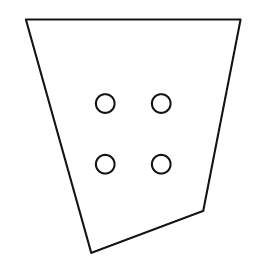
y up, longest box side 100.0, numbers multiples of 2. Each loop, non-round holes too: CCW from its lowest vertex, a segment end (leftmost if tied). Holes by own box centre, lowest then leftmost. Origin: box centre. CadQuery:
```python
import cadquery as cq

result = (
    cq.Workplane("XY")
    .moveTo(-18.0, -50.0)
    .lineTo(30.0, -32.0)
    .lineTo(46.0, 50.0)
    .lineTo(-46.0, 50.0)
    .close()
    .moveTo(-12.0, -12.0)
    .circle(4.0)
    .moveTo(12.0, -12.0)
    .circle(4.0)
    .moveTo(-12.0, 14.0)
    .circle(4.0)
    .moveTo(12.0, 14.0)
    .circle(4.0)
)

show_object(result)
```